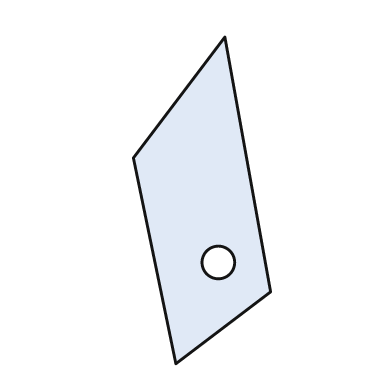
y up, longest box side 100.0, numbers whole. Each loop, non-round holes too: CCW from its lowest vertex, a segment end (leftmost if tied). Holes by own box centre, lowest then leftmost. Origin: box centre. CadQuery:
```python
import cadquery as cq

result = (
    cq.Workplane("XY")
    .moveTo(-8.0, -50.0)
    .lineTo(21.0, -28.0)
    .lineTo(7.0, 50.0)
    .lineTo(-21.0, 13.0)
    .close()
    .moveTo(5.0, -19.0)
    .circle(5.0)
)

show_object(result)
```